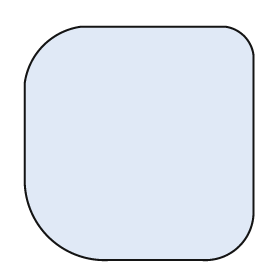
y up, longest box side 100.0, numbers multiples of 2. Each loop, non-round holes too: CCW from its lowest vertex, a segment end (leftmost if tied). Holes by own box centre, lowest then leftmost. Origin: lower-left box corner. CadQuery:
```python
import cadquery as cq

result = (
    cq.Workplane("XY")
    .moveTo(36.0, 0.0)
    .lineTo(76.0, 0.0)
    .threePointArc((92.0, 6.0), (98.0, 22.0))
    .lineTo(98.0, 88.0)
    .threePointArc((94.0, 96.0), (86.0, 100.0))
    .lineTo(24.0, 100.0)
    .threePointArc((8.0, 92.0), (0.0, 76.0))
    .lineTo(0.0, 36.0)
    .threePointArc((10.0, 10.0), (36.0, 0.0))
    .close()
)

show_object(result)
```